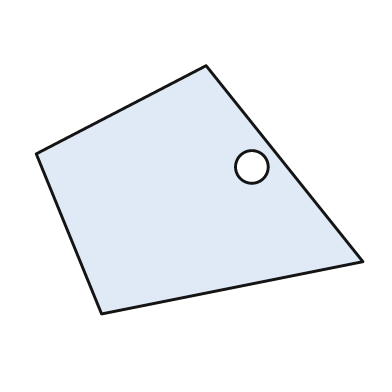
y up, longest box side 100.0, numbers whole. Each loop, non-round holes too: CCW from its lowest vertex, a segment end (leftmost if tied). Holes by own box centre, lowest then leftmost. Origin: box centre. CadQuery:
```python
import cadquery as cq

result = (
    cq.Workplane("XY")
    .moveTo(-30.0, -38.0)
    .lineTo(50.0, -22.0)
    .lineTo(2.0, 38.0)
    .lineTo(-50.0, 11.0)
    .close()
    .moveTo(16.0, 7.0)
    .circle(5.0)
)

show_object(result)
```